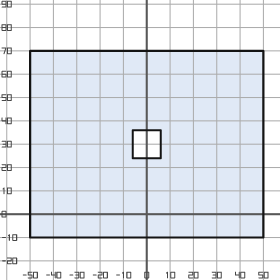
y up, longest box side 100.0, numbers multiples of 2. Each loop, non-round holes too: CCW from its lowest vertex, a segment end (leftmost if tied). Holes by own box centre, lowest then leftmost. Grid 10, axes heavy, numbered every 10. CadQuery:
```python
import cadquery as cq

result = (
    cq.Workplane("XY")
    .moveTo(-50.0, -10.0)
    .lineTo(50.0, -10.0)
    .lineTo(50.0, 70.0)
    .lineTo(-50.0, 70.0)
    .close()
    .moveTo(-6.0, 24.0)
    .lineTo(6.0, 24.0)
    .lineTo(6.0, 36.0)
    .lineTo(-6.0, 36.0)
    .close()
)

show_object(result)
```